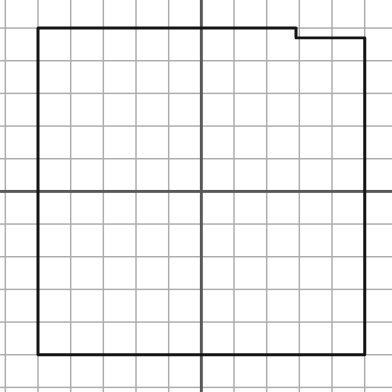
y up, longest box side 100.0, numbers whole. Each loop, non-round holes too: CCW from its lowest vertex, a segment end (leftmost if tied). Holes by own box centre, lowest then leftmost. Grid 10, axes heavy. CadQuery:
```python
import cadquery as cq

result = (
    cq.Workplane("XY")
    .moveTo(-50.0, -50.0)
    .lineTo(50.0, -50.0)
    .lineTo(50.0, 47.0)
    .lineTo(29.0, 47.0)
    .lineTo(29.0, 50.0)
    .lineTo(-50.0, 50.0)
    .close()
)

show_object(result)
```